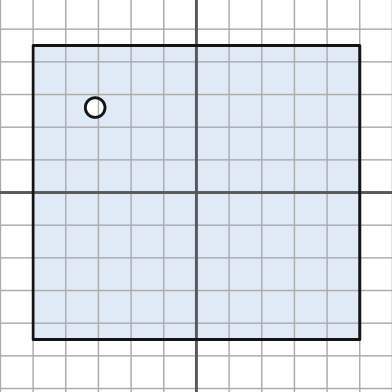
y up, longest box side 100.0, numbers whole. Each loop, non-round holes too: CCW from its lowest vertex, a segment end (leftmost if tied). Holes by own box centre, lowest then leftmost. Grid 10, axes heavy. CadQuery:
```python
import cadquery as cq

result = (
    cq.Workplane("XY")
    .moveTo(-50.0, -45.0)
    .lineTo(50.0, -45.0)
    .lineTo(50.0, 45.0)
    .lineTo(-50.0, 45.0)
    .close()
    .moveTo(-31.0, 26.0)
    .circle(3.0)
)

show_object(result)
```